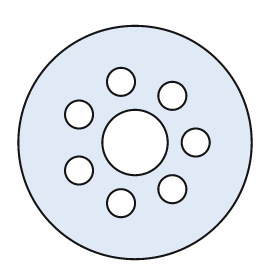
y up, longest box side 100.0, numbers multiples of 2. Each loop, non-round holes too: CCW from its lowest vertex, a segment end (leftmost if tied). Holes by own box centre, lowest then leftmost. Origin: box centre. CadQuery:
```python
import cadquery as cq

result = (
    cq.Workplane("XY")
    .moveTo(0.0, 0.0)
    .circle(50.0)
    .moveTo(-6.0, -26.0)
    .circle(6.0)
    .moveTo(16.0, -20.0)
    .circle(6.0)
    .moveTo(-24.0, -12.0)
    .circle(6.0)
    .moveTo(0.0, 0.0)
    .circle(14.0)
    .moveTo(26.0, 0.0)
    .circle(6.0)
    .moveTo(-24.0, 12.0)
    .circle(6.0)
    .moveTo(16.0, 20.0)
    .circle(6.0)
    .moveTo(-6.0, 26.0)
    .circle(6.0)
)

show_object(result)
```